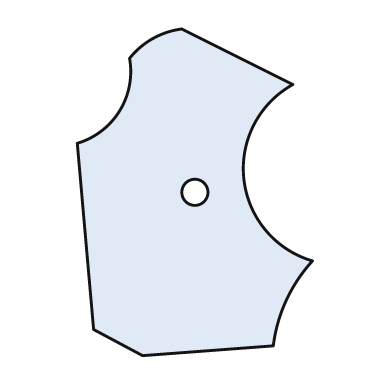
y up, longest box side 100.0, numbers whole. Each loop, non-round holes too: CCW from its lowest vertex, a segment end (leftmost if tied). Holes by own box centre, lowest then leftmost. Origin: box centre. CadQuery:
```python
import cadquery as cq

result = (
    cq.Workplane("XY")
    .moveTo(-16.0, -50.0)
    .lineTo(24.0, -47.0)
    .threePointArc((28.0, -33.0), (36.0, -21.0))
    .threePointArc((15.0, 4.0), (30.0, 33.0))
    .lineTo(-4.0, 50.0)
    .threePointArc((-13.0, 47.0), (-20.0, 41.0))
    .threePointArc((-23.0, 25.0), (-36.0, 15.0))
    .lineTo(-31.0, -42.0)
    .close()
    .moveTo(0.0, 0.0)
    .circle(4.0)
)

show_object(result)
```